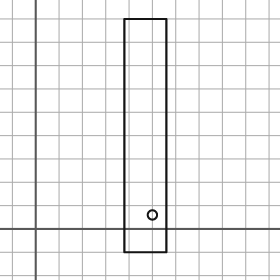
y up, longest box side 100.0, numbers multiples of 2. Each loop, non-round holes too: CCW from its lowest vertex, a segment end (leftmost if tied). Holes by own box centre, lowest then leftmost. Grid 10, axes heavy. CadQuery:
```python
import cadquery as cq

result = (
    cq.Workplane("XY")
    .moveTo(38.0, -10.0)
    .lineTo(56.0, -10.0)
    .lineTo(56.0, 90.0)
    .lineTo(38.0, 90.0)
    .close()
    .moveTo(50.0, 6.0)
    .circle(2.0)
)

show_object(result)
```